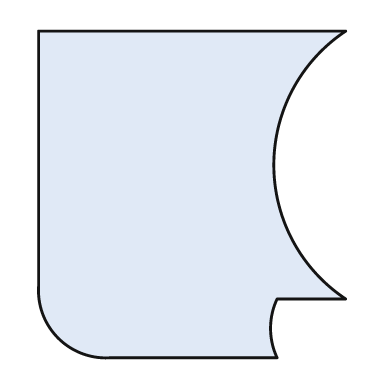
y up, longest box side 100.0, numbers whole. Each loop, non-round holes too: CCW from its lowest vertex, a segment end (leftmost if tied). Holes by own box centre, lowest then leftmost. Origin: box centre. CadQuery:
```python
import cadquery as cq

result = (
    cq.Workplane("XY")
    .moveTo(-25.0, -50.0)
    .lineTo(26.0, -50.0)
    .threePointArc((24.0, -41.0), (26.0, -32.0))
    .lineTo(47.0, -32.0)
    .threePointArc((25.0, 9.0), (47.0, 50.0))
    .lineTo(-47.0, 50.0)
    .lineTo(-47.0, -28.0)
    .threePointArc((-41.0, -44.0), (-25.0, -50.0))
    .close()
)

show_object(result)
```